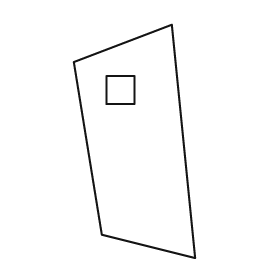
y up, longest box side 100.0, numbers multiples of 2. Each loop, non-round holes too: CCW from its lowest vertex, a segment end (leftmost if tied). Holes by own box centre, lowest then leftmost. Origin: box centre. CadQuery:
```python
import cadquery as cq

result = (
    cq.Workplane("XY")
    .moveTo(26.0, -50.0)
    .lineTo(16.0, 50.0)
    .lineTo(-26.0, 34.0)
    .lineTo(-14.0, -40.0)
    .close()
    .moveTo(-12.0, 16.0)
    .lineTo(0.0, 16.0)
    .lineTo(0.0, 28.0)
    .lineTo(-12.0, 28.0)
    .close()
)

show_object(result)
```